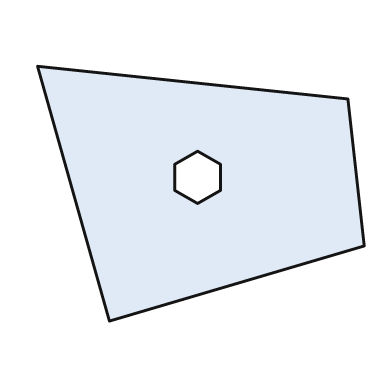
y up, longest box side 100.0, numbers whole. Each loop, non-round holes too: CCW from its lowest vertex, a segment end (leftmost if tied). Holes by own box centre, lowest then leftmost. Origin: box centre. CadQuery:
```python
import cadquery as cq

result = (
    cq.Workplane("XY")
    .moveTo(-28.0, -39.0)
    .lineTo(50.0, -16.0)
    .lineTo(45.0, 29.0)
    .lineTo(-50.0, 39.0)
    .close()
    .moveTo(-1.0, -3.0)
    .lineTo(6.0, 1.0)
    .lineTo(6.0, 9.0)
    .lineTo(-1.0, 13.0)
    .lineTo(-8.0, 9.0)
    .lineTo(-8.0, 1.0)
    .close()
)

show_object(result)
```